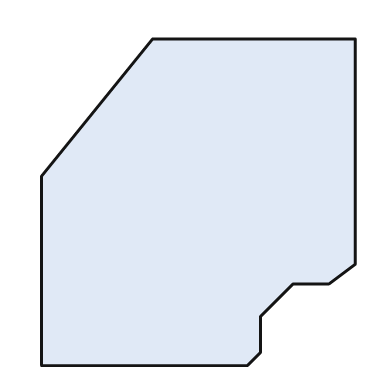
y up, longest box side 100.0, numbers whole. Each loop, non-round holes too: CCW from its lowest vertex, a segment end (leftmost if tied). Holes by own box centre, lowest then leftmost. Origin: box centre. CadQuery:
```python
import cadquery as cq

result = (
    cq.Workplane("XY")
    .moveTo(-48.0, -50.0)
    .lineTo(15.0, -50.0)
    .lineTo(19.0, -46.0)
    .lineTo(19.0, -35.0)
    .lineTo(29.0, -25.0)
    .lineTo(40.0, -25.0)
    .lineTo(48.0, -19.0)
    .lineTo(48.0, 50.0)
    .lineTo(-14.0, 50.0)
    .lineTo(-48.0, 8.0)
    .close()
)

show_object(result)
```